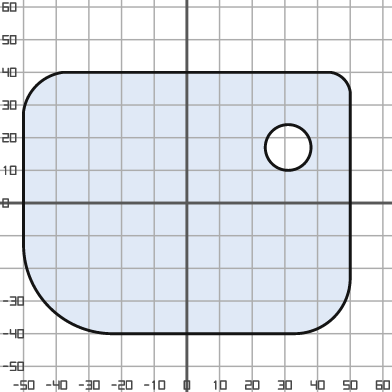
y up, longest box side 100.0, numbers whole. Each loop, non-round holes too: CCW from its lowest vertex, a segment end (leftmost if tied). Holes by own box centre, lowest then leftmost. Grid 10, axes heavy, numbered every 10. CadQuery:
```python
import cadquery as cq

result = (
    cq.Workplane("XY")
    .moveTo(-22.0, -40.0)
    .lineTo(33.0, -40.0)
    .threePointArc((45.0, -35.0), (50.0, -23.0))
    .lineTo(50.0, 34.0)
    .threePointArc((48.0, 38.0), (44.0, 40.0))
    .lineTo(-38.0, 40.0)
    .threePointArc((-46.0, 36.0), (-50.0, 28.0))
    .lineTo(-50.0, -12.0)
    .threePointArc((-42.0, -32.0), (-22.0, -40.0))
    .close()
    .moveTo(31.0, 17.0)
    .circle(7.0)
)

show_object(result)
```